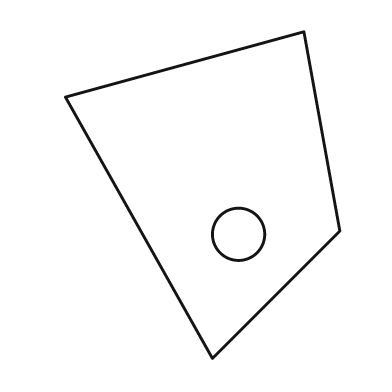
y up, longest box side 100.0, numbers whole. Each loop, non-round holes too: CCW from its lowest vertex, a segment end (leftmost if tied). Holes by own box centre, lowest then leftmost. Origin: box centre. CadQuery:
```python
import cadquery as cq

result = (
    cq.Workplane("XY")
    .moveTo(3.0, -50.0)
    .lineTo(42.0, -11.0)
    .lineTo(31.0, 50.0)
    .lineTo(-42.0, 30.0)
    .close()
    .moveTo(11.0, -12.0)
    .circle(8.0)
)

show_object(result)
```